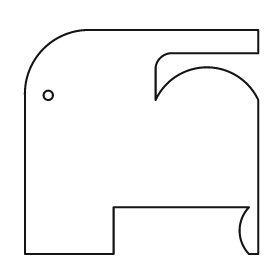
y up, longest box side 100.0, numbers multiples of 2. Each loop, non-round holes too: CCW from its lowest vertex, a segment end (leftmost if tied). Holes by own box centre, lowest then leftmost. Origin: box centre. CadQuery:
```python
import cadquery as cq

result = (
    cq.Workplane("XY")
    .moveTo(-50.0, -48.0)
    .lineTo(-12.0, -48.0)
    .lineTo(-12.0, -28.0)
    .lineTo(46.0, -28.0)
    .threePointArc((42.0, -38.0), (46.0, -48.0))
    .lineTo(50.0, -48.0)
    .lineTo(50.0, 18.0)
    .threePointArc((28.0, 32.0), (6.0, 18.0))
    .lineTo(6.0, 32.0)
    .threePointArc((8.0, 36.0), (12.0, 38.0))
    .lineTo(50.0, 38.0)
    .lineTo(50.0, 48.0)
    .lineTo(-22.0, 48.0)
    .threePointArc((-42.0, 40.0), (-50.0, 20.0))
    .close()
    .moveTo(-40.0, 20.0)
    .circle(2.0)
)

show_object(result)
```